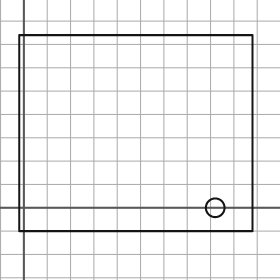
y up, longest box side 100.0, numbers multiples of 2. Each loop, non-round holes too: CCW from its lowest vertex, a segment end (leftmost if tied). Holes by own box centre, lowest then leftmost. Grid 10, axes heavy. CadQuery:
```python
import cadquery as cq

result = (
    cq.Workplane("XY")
    .moveTo(-2.0, -10.0)
    .lineTo(98.0, -10.0)
    .lineTo(98.0, 74.0)
    .lineTo(-2.0, 74.0)
    .close()
    .moveTo(82.0, 0.0)
    .circle(4.0)
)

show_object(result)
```